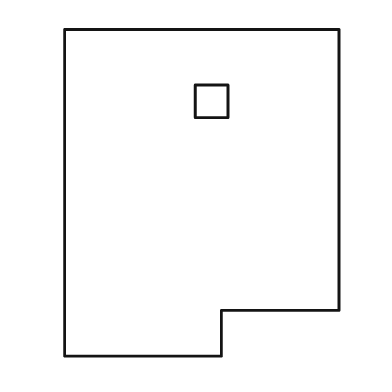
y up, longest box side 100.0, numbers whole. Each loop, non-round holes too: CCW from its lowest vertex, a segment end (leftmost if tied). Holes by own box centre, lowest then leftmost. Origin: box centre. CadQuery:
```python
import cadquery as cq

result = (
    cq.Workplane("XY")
    .moveTo(-42.0, -50.0)
    .lineTo(6.0, -50.0)
    .lineTo(6.0, -36.0)
    .lineTo(42.0, -36.0)
    .lineTo(42.0, 50.0)
    .lineTo(-42.0, 50.0)
    .close()
    .moveTo(-2.0, 23.0)
    .lineTo(8.0, 23.0)
    .lineTo(8.0, 33.0)
    .lineTo(-2.0, 33.0)
    .close()
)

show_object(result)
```